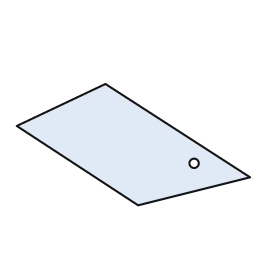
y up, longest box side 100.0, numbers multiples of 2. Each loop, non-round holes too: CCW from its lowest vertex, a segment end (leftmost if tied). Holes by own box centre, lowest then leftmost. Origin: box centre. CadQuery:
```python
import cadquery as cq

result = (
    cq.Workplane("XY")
    .moveTo(2.0, -26.0)
    .lineTo(50.0, -14.0)
    .lineTo(-12.0, 26.0)
    .lineTo(-50.0, 8.0)
    .close()
    .moveTo(26.0, -8.0)
    .circle(2.0)
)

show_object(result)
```